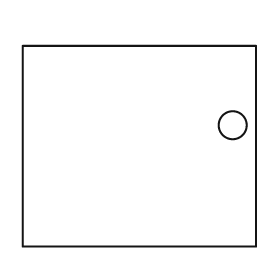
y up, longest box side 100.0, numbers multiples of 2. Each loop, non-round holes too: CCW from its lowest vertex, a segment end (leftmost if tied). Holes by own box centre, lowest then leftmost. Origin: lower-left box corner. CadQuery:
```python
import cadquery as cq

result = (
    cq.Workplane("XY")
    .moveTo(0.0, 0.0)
    .lineTo(100.0, 0.0)
    .lineTo(100.0, 86.0)
    .lineTo(0.0, 86.0)
    .close()
    .moveTo(90.0, 52.0)
    .circle(6.0)
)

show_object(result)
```